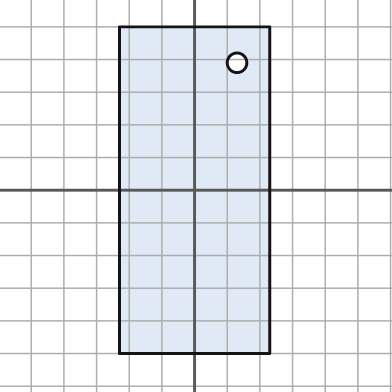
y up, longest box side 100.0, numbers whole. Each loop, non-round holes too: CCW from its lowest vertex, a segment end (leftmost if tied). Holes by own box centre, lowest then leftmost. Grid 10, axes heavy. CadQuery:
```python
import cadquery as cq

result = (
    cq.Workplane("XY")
    .moveTo(-23.0, -50.0)
    .lineTo(23.0, -50.0)
    .lineTo(23.0, 50.0)
    .lineTo(-23.0, 50.0)
    .close()
    .moveTo(13.0, 39.0)
    .circle(3.0)
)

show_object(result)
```